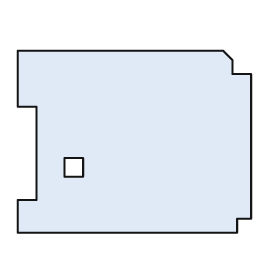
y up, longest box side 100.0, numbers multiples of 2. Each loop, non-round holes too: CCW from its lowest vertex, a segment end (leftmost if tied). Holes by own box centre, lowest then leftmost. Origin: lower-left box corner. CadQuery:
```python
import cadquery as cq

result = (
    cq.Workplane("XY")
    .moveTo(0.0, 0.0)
    .lineTo(94.0, 0.0)
    .lineTo(94.0, 6.0)
    .lineTo(100.0, 6.0)
    .lineTo(100.0, 68.0)
    .lineTo(92.0, 68.0)
    .lineTo(92.0, 74.0)
    .lineTo(88.0, 78.0)
    .lineTo(0.0, 78.0)
    .lineTo(0.0, 54.0)
    .lineTo(8.0, 54.0)
    .lineTo(8.0, 14.0)
    .lineTo(0.0, 14.0)
    .close()
    .moveTo(20.0, 24.0)
    .lineTo(28.0, 24.0)
    .lineTo(28.0, 32.0)
    .lineTo(20.0, 32.0)
    .close()
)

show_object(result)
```